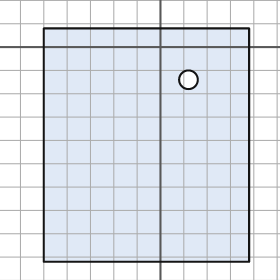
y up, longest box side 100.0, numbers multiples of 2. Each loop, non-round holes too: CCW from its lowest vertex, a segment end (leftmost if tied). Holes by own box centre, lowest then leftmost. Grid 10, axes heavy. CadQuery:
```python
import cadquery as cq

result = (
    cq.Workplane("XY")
    .moveTo(-50.0, -92.0)
    .lineTo(38.0, -92.0)
    .lineTo(38.0, 8.0)
    .lineTo(-50.0, 8.0)
    .close()
    .moveTo(12.0, -14.0)
    .circle(4.0)
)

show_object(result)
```